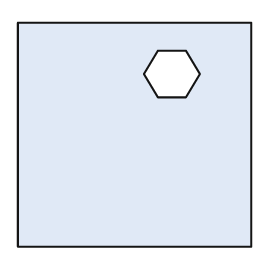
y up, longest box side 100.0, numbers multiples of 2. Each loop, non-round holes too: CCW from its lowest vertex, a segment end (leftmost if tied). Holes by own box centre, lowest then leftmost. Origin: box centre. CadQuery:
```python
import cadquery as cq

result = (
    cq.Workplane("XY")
    .moveTo(-50.0, -48.0)
    .lineTo(50.0, -48.0)
    .lineTo(50.0, 48.0)
    .lineTo(-50.0, 48.0)
    .close()
    .moveTo(10.0, 16.0)
    .lineTo(22.0, 16.0)
    .lineTo(28.0, 26.0)
    .lineTo(22.0, 36.0)
    .lineTo(10.0, 36.0)
    .lineTo(4.0, 26.0)
    .close()
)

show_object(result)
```